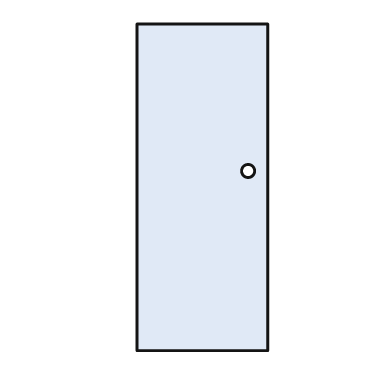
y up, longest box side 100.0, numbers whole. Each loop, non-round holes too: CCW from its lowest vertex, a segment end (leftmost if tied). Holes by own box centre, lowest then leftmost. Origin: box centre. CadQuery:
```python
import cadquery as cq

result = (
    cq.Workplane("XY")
    .moveTo(-20.0, -50.0)
    .lineTo(20.0, -50.0)
    .lineTo(20.0, 50.0)
    .lineTo(-20.0, 50.0)
    .close()
    .moveTo(14.0, 5.0)
    .circle(2.0)
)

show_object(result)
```